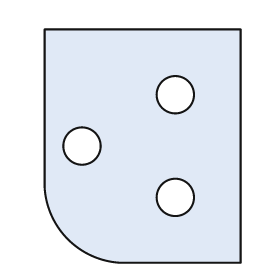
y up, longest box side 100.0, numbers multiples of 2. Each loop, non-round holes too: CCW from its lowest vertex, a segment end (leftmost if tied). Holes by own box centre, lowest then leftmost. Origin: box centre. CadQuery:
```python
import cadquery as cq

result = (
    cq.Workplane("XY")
    .moveTo(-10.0, -50.0)
    .lineTo(42.0, -50.0)
    .lineTo(42.0, 50.0)
    .lineTo(-42.0, 50.0)
    .lineTo(-42.0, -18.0)
    .threePointArc((-32.0, -40.0), (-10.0, -50.0))
    .close()
    .moveTo(14.0, -22.0)
    .circle(8.0)
    .moveTo(-26.0, 0.0)
    .circle(8.0)
    .moveTo(14.0, 22.0)
    .circle(8.0)
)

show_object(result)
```